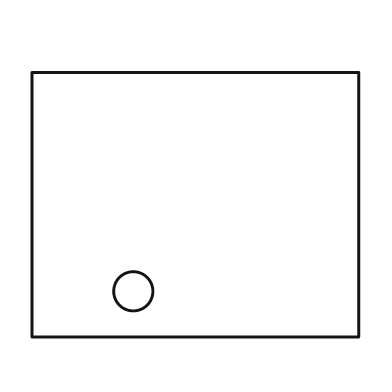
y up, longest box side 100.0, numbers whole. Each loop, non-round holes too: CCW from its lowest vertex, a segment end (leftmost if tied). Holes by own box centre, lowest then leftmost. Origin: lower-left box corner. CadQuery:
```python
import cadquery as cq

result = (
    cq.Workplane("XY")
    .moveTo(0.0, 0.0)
    .lineTo(100.0, 0.0)
    .lineTo(100.0, 81.0)
    .lineTo(0.0, 81.0)
    .close()
    .moveTo(31.0, 14.0)
    .circle(6.0)
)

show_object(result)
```